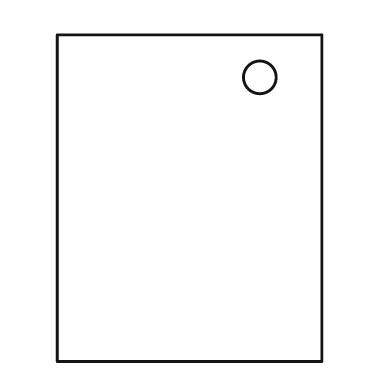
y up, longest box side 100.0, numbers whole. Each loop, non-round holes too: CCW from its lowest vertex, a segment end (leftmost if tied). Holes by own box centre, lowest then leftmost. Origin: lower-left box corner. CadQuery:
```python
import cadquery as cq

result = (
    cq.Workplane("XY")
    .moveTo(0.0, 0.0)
    .lineTo(81.0, 0.0)
    .lineTo(81.0, 100.0)
    .lineTo(0.0, 100.0)
    .close()
    .moveTo(62.0, 87.0)
    .circle(5.0)
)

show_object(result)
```